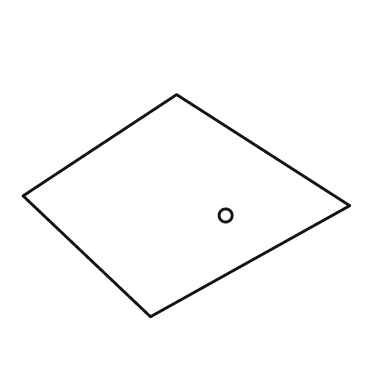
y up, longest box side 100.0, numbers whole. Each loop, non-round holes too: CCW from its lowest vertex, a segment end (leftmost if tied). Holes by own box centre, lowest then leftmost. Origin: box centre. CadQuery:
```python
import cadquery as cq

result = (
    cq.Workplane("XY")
    .moveTo(-11.0, -34.0)
    .lineTo(50.0, 0.0)
    .lineTo(-3.0, 34.0)
    .lineTo(-50.0, 3.0)
    .close()
    .moveTo(12.0, -3.0)
    .circle(2.0)
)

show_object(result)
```